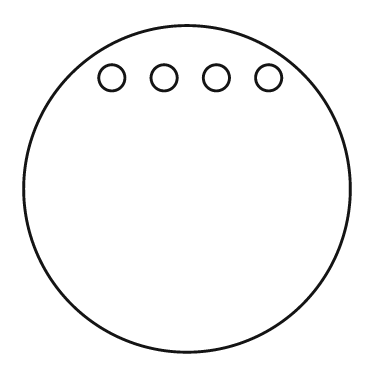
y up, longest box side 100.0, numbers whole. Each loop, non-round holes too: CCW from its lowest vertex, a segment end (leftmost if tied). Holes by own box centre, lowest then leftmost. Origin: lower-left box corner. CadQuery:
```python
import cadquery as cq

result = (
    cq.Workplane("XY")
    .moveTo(50.0, 50.0)
    .circle(50.0)
    .moveTo(27.0, 84.0)
    .circle(4.0)
    .moveTo(43.0, 84.0)
    .circle(4.0)
    .moveTo(59.0, 84.0)
    .circle(4.0)
    .moveTo(75.0, 84.0)
    .circle(4.0)
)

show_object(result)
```